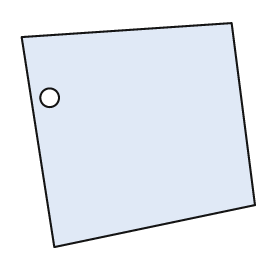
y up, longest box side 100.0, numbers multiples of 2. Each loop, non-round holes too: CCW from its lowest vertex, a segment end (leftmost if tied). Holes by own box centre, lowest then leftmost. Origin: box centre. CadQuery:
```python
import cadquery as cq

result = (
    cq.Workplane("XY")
    .moveTo(-36.0, -48.0)
    .lineTo(50.0, -30.0)
    .lineTo(40.0, 48.0)
    .lineTo(-50.0, 42.0)
    .close()
    .moveTo(-38.0, 16.0)
    .circle(4.0)
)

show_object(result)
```